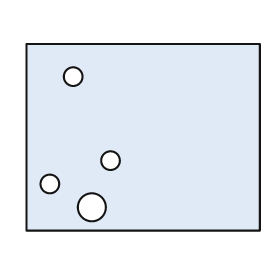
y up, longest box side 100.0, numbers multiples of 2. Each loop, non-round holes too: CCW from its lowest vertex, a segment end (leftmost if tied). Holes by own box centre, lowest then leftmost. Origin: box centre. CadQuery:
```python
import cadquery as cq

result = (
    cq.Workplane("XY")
    .moveTo(-50.0, -40.0)
    .lineTo(50.0, -40.0)
    .lineTo(50.0, 40.0)
    .lineTo(-50.0, 40.0)
    .close()
    .moveTo(-22.0, -30.0)
    .circle(6.0)
    .moveTo(-40.0, -20.0)
    .circle(4.0)
    .moveTo(-14.0, -10.0)
    .circle(4.0)
    .moveTo(-30.0, 26.0)
    .circle(4.0)
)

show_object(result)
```